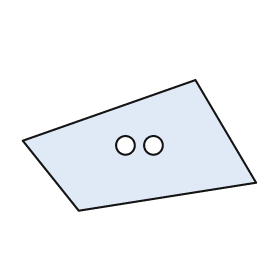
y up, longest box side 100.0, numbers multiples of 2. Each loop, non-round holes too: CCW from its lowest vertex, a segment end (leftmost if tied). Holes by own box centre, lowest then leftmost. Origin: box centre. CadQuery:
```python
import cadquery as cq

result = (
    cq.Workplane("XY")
    .moveTo(-26.0, -28.0)
    .lineTo(50.0, -16.0)
    .lineTo(24.0, 28.0)
    .lineTo(-50.0, 2.0)
    .close()
    .moveTo(-6.0, 0.0)
    .circle(4.0)
    .moveTo(6.0, 0.0)
    .circle(4.0)
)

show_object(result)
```